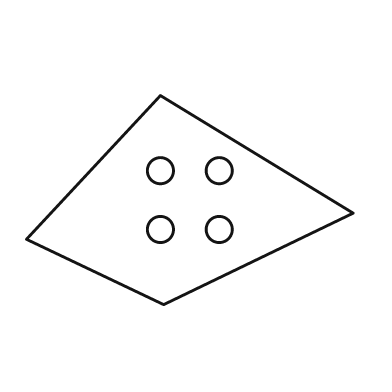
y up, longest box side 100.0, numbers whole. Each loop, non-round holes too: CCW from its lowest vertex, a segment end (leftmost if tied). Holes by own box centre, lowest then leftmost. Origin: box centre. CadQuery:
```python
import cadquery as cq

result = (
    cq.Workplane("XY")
    .moveTo(-8.0, -32.0)
    .lineTo(50.0, -4.0)
    .lineTo(-9.0, 32.0)
    .lineTo(-50.0, -12.0)
    .close()
    .moveTo(-9.0, -9.0)
    .circle(4.0)
    .moveTo(9.0, -9.0)
    .circle(4.0)
    .moveTo(-9.0, 9.0)
    .circle(4.0)
    .moveTo(9.0, 9.0)
    .circle(4.0)
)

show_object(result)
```